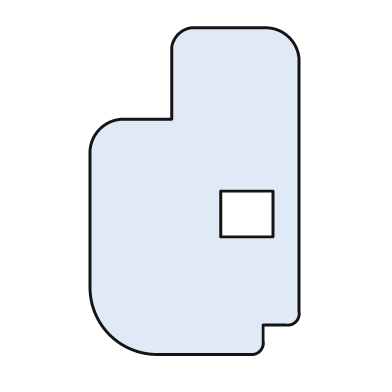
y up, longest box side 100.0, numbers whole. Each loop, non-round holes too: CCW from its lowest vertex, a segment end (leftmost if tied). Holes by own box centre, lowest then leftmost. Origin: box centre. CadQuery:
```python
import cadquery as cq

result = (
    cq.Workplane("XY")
    .moveTo(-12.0, -50.0)
    .lineTo(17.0, -50.0)
    .threePointArc((20.0, -49.0), (21.0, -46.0))
    .lineTo(21.0, -41.0)
    .lineTo(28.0, -41.0)
    .threePointArc((31.0, -40.0), (32.0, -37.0))
    .lineTo(32.0, 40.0)
    .threePointArc((29.0, 47.0), (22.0, 50.0))
    .lineTo(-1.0, 50.0)
    .threePointArc((-5.0, 48.0), (-7.0, 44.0))
    .lineTo(-7.0, 22.0)
    .lineTo(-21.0, 22.0)
    .threePointArc((-29.0, 19.0), (-32.0, 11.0))
    .lineTo(-32.0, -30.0)
    .threePointArc((-26.0, -44.0), (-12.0, -50.0))
    .close()
    .moveTo(8.0, -14.0)
    .lineTo(24.0, -14.0)
    .lineTo(24.0, 0.0)
    .lineTo(8.0, 0.0)
    .close()
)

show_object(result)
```